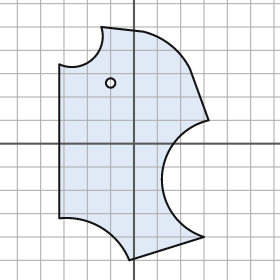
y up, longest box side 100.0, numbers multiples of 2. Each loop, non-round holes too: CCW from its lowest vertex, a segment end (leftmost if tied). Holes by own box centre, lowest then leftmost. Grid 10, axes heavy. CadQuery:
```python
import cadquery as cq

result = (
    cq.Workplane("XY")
    .moveTo(-2.0, -50.0)
    .lineTo(30.0, -40.0)
    .threePointArc((12.0, -14.0), (32.0, 10.0))
    .lineTo(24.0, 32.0)
    .threePointArc((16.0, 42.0), (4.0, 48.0))
    .lineTo(-14.0, 50.0)
    .threePointArc((-18.0, 36.0), (-32.0, 34.0))
    .lineTo(-32.0, -32.0)
    .threePointArc((-14.0, -36.0), (-2.0, -50.0))
    .close()
    .moveTo(-10.0, 26.0)
    .circle(2.0)
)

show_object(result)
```